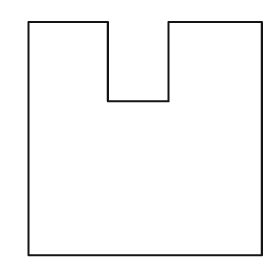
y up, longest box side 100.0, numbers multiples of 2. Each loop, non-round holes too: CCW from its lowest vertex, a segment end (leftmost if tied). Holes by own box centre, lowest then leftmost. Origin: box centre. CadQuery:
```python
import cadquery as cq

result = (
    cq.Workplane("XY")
    .moveTo(-50.0, -50.0)
    .lineTo(50.0, -50.0)
    .lineTo(50.0, 50.0)
    .lineTo(10.0, 50.0)
    .lineTo(10.0, 16.0)
    .lineTo(-16.0, 16.0)
    .lineTo(-16.0, 50.0)
    .lineTo(-50.0, 50.0)
    .close()
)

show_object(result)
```